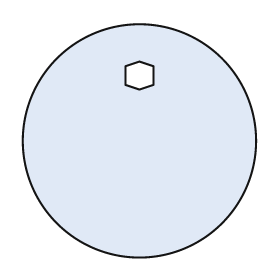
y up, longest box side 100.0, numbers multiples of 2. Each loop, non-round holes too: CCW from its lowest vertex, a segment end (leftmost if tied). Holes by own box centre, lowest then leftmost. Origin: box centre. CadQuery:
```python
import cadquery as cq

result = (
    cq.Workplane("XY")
    .moveTo(0.0, 0.0)
    .circle(50.0)
    .moveTo(0.0, 22.0)
    .lineTo(6.0, 24.0)
    .lineTo(6.0, 32.0)
    .lineTo(0.0, 34.0)
    .lineTo(-6.0, 32.0)
    .lineTo(-6.0, 24.0)
    .close()
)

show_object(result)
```